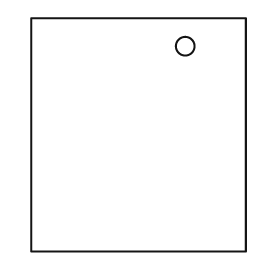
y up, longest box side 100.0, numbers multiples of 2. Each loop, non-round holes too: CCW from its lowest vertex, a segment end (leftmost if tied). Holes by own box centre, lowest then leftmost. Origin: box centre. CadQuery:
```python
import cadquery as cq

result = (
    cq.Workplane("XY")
    .moveTo(-46.0, -50.0)
    .lineTo(46.0, -50.0)
    .lineTo(46.0, 50.0)
    .lineTo(-46.0, 50.0)
    .close()
    .moveTo(20.0, 38.0)
    .circle(4.0)
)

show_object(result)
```